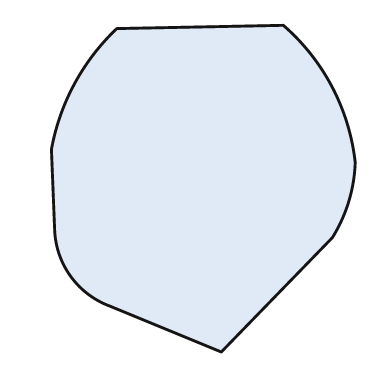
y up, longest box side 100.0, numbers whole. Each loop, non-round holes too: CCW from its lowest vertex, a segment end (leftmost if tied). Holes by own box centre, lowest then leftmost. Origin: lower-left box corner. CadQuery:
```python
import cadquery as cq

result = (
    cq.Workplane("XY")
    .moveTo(52.0, 0.0)
    .lineTo(86.0, 35.0)
    .threePointArc((91.0, 46.0), (93.0, 58.0))
    .threePointArc((86.0, 81.0), (71.0, 100.0))
    .lineTo(20.0, 99.0)
    .threePointArc((7.0, 82.0), (0.0, 62.0))
    .lineTo(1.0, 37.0)
    .threePointArc((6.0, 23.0), (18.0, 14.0))
    .close()
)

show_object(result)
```